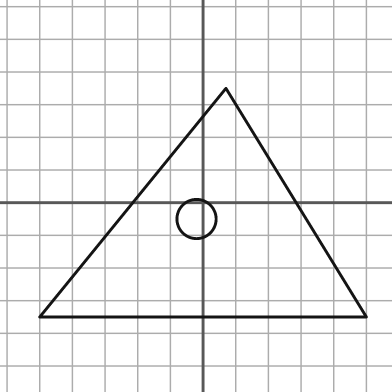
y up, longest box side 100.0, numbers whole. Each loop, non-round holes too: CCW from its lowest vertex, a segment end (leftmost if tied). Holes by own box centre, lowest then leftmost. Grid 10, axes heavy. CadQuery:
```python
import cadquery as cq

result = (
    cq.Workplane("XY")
    .moveTo(-50.0, -35.0)
    .lineTo(50.0, -35.0)
    .lineTo(7.0, 35.0)
    .close()
    .moveTo(-2.0, -5.0)
    .circle(6.0)
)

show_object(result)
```